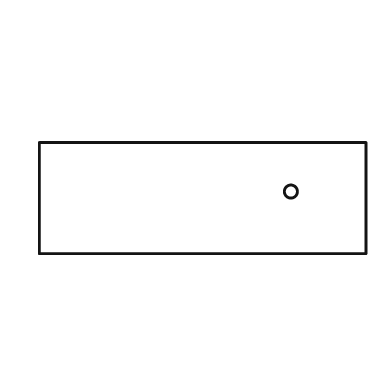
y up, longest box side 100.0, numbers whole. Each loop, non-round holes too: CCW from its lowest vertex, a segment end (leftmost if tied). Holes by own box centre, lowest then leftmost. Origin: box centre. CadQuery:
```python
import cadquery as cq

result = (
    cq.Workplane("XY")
    .moveTo(-50.0, -17.0)
    .lineTo(50.0, -17.0)
    .lineTo(50.0, 17.0)
    .lineTo(-50.0, 17.0)
    .close()
    .moveTo(27.0, 2.0)
    .circle(2.0)
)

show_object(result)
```